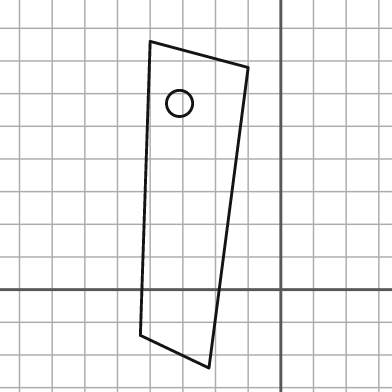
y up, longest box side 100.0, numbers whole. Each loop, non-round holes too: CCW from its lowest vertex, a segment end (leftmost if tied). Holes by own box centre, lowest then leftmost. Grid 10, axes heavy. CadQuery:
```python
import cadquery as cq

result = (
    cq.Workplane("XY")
    .moveTo(-22.0, -24.0)
    .lineTo(-10.0, 68.0)
    .lineTo(-40.0, 76.0)
    .lineTo(-43.0, -14.0)
    .close()
    .moveTo(-31.0, 57.0)
    .circle(4.0)
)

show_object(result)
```